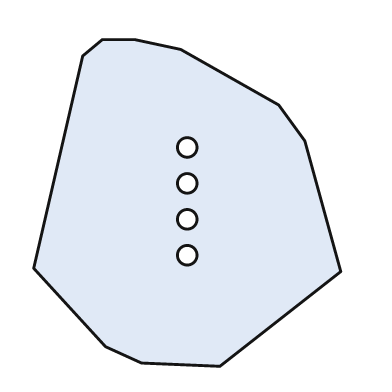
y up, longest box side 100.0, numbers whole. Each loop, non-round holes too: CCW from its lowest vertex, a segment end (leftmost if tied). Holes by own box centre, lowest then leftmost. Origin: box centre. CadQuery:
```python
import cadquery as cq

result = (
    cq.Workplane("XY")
    .moveTo(10.0, -50.0)
    .lineTo(47.0, -21.0)
    .lineTo(36.0, 19.0)
    .lineTo(28.0, 30.0)
    .lineTo(-2.0, 47.0)
    .lineTo(-16.0, 50.0)
    .lineTo(-26.0, 50.0)
    .lineTo(-32.0, 45.0)
    .lineTo(-47.0, -20.0)
    .lineTo(-25.0, -44.0)
    .lineTo(-14.0, -49.0)
    .close()
    .moveTo(0.0, -16.0)
    .circle(3.0)
    .moveTo(0.0, -5.0)
    .circle(3.0)
    .moveTo(0.0, 6.0)
    .circle(3.0)
    .moveTo(0.0, 17.0)
    .circle(3.0)
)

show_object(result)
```